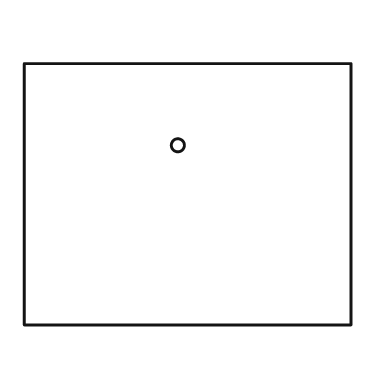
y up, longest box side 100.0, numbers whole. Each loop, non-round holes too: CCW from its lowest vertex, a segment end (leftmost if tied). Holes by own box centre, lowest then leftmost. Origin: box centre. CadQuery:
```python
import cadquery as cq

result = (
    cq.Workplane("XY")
    .moveTo(-50.0, -40.0)
    .lineTo(50.0, -40.0)
    .lineTo(50.0, 40.0)
    .lineTo(-50.0, 40.0)
    .close()
    .moveTo(-3.0, 15.0)
    .circle(2.0)
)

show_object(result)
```